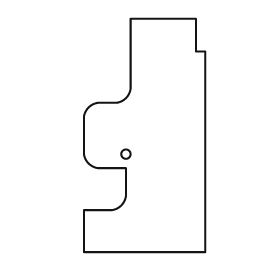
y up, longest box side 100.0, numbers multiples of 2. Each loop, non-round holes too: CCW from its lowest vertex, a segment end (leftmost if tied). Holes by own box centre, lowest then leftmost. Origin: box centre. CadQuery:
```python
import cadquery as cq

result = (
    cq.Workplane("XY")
    .moveTo(-26.0, -50.0)
    .lineTo(26.0, -50.0)
    .lineTo(26.0, 36.0)
    .lineTo(22.0, 36.0)
    .lineTo(22.0, 50.0)
    .lineTo(-6.0, 50.0)
    .lineTo(-6.0, 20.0)
    .threePointArc((-8.0, 16.0), (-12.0, 14.0))
    .lineTo(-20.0, 14.0)
    .threePointArc((-24.0, 12.0), (-26.0, 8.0))
    .lineTo(-26.0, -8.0)
    .threePointArc((-24.0, -12.0), (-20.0, -14.0))
    .lineTo(-8.0, -14.0)
    .lineTo(-8.0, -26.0)
    .threePointArc((-10.0, -30.0), (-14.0, -32.0))
    .lineTo(-26.0, -32.0)
    .close()
    .moveTo(-8.0, -8.0)
    .circle(2.0)
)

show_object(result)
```